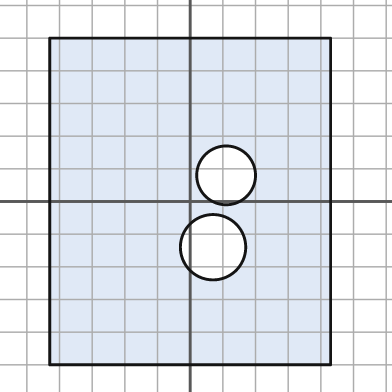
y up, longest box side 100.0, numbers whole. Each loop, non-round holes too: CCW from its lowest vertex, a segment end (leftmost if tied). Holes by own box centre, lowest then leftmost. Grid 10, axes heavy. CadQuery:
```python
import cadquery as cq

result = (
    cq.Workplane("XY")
    .moveTo(-43.0, -50.0)
    .lineTo(43.0, -50.0)
    .lineTo(43.0, 50.0)
    .lineTo(-43.0, 50.0)
    .close()
    .moveTo(7.0, -14.0)
    .circle(10.0)
    .moveTo(11.0, 8.0)
    .circle(9.0)
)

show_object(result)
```